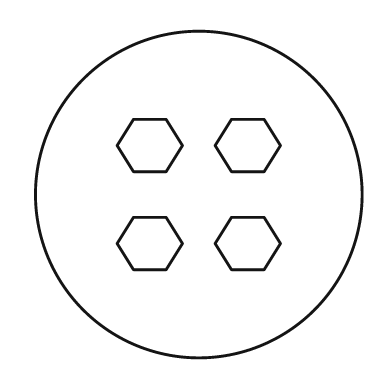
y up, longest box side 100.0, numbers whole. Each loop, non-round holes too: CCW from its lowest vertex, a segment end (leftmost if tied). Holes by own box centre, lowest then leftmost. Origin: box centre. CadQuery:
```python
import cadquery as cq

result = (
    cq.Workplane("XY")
    .moveTo(0.0, 0.0)
    .circle(50.0)
    .moveTo(-20.0, -23.0)
    .lineTo(-10.0, -23.0)
    .lineTo(-5.0, -15.0)
    .lineTo(-10.0, -7.0)
    .lineTo(-20.0, -7.0)
    .lineTo(-25.0, -15.0)
    .close()
    .moveTo(10.0, -23.0)
    .lineTo(20.0, -23.0)
    .lineTo(25.0, -15.0)
    .lineTo(20.0, -7.0)
    .lineTo(10.0, -7.0)
    .lineTo(5.0, -15.0)
    .close()
    .moveTo(-20.0, 7.0)
    .lineTo(-10.0, 7.0)
    .lineTo(-5.0, 15.0)
    .lineTo(-10.0, 23.0)
    .lineTo(-20.0, 23.0)
    .lineTo(-25.0, 15.0)
    .close()
    .moveTo(10.0, 7.0)
    .lineTo(20.0, 7.0)
    .lineTo(25.0, 15.0)
    .lineTo(20.0, 23.0)
    .lineTo(10.0, 23.0)
    .lineTo(5.0, 15.0)
    .close()
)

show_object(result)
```